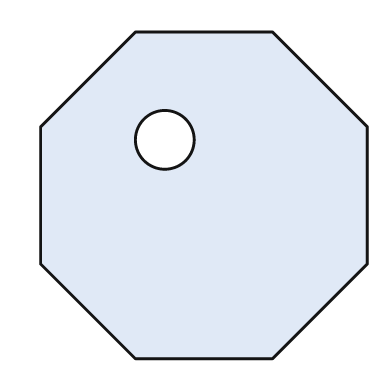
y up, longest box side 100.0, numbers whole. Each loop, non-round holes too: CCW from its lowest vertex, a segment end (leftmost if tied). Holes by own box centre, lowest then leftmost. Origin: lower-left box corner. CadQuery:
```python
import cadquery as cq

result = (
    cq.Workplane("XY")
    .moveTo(29.0, 0.0)
    .lineTo(71.0, 0.0)
    .lineTo(100.0, 29.0)
    .lineTo(100.0, 71.0)
    .lineTo(71.0, 100.0)
    .lineTo(29.0, 100.0)
    .lineTo(0.0, 71.0)
    .lineTo(0.0, 29.0)
    .close()
    .moveTo(38.0, 67.0)
    .circle(9.0)
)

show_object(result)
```